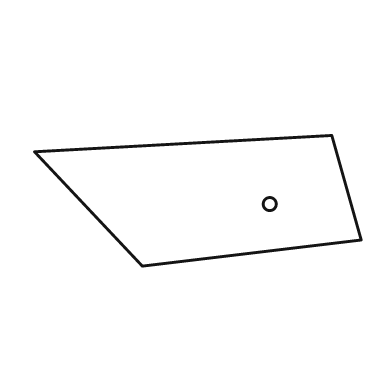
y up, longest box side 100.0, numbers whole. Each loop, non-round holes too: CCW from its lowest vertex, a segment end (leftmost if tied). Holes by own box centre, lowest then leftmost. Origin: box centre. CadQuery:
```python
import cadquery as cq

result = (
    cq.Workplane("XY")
    .moveTo(-17.0, -20.0)
    .lineTo(50.0, -12.0)
    .lineTo(41.0, 20.0)
    .lineTo(-50.0, 15.0)
    .close()
    .moveTo(22.0, -1.0)
    .circle(2.0)
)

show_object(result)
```